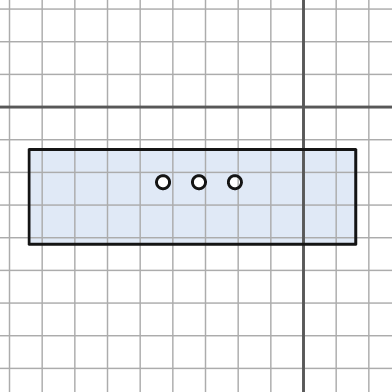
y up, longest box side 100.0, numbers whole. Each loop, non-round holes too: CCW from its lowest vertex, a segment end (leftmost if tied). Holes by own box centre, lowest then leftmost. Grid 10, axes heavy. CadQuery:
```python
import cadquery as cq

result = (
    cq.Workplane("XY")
    .moveTo(-84.0, -42.0)
    .lineTo(16.0, -42.0)
    .lineTo(16.0, -13.0)
    .lineTo(-84.0, -13.0)
    .close()
    .moveTo(-43.0, -23.0)
    .circle(2.0)
    .moveTo(-32.0, -23.0)
    .circle(2.0)
    .moveTo(-21.0, -23.0)
    .circle(2.0)
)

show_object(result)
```